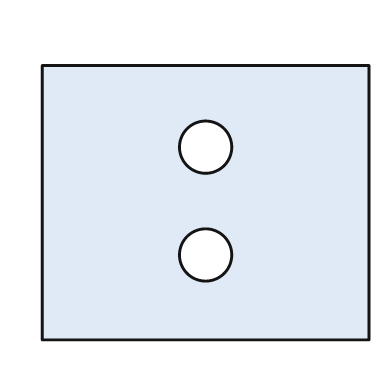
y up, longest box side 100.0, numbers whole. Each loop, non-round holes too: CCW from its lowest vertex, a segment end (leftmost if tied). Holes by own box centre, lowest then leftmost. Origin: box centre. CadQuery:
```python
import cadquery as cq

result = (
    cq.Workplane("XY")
    .moveTo(-50.0, -42.0)
    .lineTo(50.0, -42.0)
    .lineTo(50.0, 42.0)
    .lineTo(-50.0, 42.0)
    .close()
    .moveTo(0.0, -16.0)
    .circle(8.0)
    .moveTo(0.0, 17.0)
    .circle(8.0)
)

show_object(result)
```